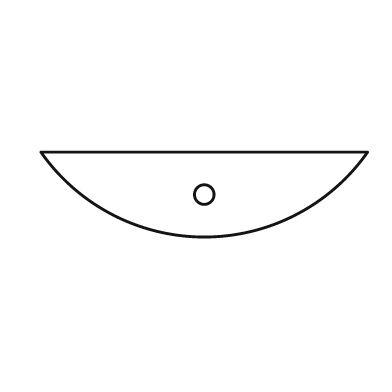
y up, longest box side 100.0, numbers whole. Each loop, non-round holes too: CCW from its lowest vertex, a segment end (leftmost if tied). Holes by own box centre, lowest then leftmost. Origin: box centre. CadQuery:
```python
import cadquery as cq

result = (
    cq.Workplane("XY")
    .moveTo(-50.0, 13.0)
    .threePointArc((0.0, -13.0), (50.0, 13.0))
    .close()
    .moveTo(0.0, 0.0)
    .circle(3.0)
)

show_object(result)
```